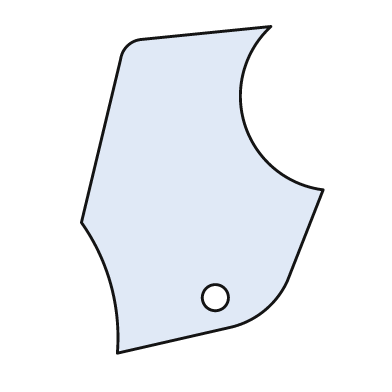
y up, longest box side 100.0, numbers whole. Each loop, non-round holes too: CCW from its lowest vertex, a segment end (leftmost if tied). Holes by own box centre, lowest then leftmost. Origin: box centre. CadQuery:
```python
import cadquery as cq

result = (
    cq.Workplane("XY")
    .moveTo(-26.0, -50.0)
    .lineTo(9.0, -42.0)
    .threePointArc((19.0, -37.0), (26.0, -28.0))
    .lineTo(37.0, 0.0)
    .threePointArc((13.0, 20.0), (21.0, 50.0))
    .lineTo(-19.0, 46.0)
    .threePointArc((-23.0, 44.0), (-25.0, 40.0))
    .lineTo(-37.0, -10.0)
    .threePointArc((-28.0, -29.0), (-26.0, -50.0))
    .close()
    .moveTo(4.0, -33.0)
    .circle(4.0)
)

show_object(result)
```